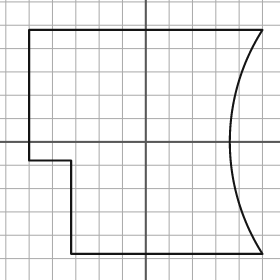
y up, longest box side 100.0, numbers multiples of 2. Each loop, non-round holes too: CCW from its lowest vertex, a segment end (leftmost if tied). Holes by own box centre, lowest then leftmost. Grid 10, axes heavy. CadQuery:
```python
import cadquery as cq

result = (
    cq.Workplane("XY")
    .moveTo(-32.0, -48.0)
    .lineTo(50.0, -48.0)
    .threePointArc((36.0, 0.0), (50.0, 48.0))
    .lineTo(-50.0, 48.0)
    .lineTo(-50.0, -8.0)
    .lineTo(-32.0, -8.0)
    .close()
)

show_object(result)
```